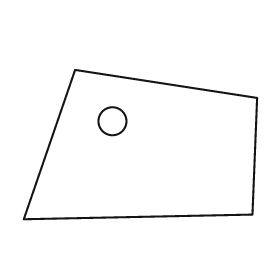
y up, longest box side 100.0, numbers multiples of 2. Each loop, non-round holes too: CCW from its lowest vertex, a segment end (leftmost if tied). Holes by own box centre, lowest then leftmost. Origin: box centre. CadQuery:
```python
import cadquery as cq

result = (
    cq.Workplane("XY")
    .moveTo(-50.0, -32.0)
    .lineTo(48.0, -30.0)
    .lineTo(50.0, 20.0)
    .lineTo(-28.0, 32.0)
    .close()
    .moveTo(-12.0, 10.0)
    .circle(6.0)
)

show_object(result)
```